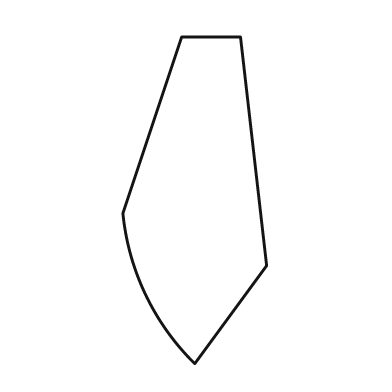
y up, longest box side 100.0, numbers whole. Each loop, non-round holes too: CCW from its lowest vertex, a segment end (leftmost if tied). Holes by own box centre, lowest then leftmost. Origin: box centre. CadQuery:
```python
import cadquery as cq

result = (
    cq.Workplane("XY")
    .moveTo(0.0, -50.0)
    .lineTo(22.0, -20.0)
    .lineTo(14.0, 50.0)
    .lineTo(-4.0, 50.0)
    .lineTo(-22.0, -4.0)
    .threePointArc((-15.0, -29.0), (0.0, -50.0))
    .close()
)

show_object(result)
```